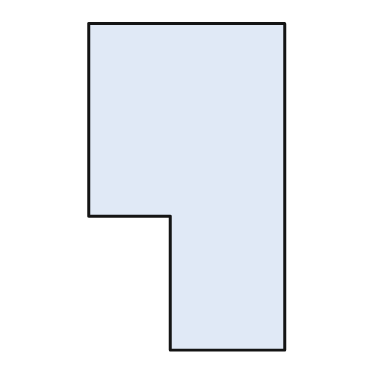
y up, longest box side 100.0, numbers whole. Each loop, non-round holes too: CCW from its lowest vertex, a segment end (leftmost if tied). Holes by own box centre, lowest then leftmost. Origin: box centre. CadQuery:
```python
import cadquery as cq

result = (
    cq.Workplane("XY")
    .moveTo(-5.0, -50.0)
    .lineTo(30.0, -50.0)
    .lineTo(30.0, 50.0)
    .lineTo(-30.0, 50.0)
    .lineTo(-30.0, -9.0)
    .lineTo(-5.0, -9.0)
    .close()
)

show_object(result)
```